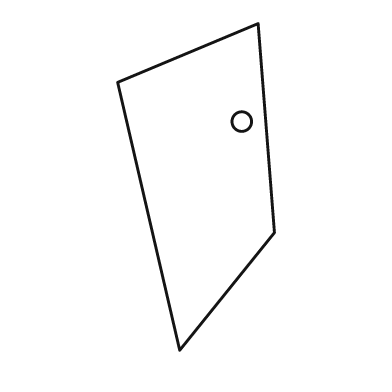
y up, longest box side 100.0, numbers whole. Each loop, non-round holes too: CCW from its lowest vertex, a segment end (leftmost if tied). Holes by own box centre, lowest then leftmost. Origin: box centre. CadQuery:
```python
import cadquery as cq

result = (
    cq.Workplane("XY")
    .moveTo(-5.0, -50.0)
    .lineTo(24.0, -14.0)
    .lineTo(19.0, 50.0)
    .lineTo(-24.0, 32.0)
    .close()
    .moveTo(14.0, 20.0)
    .circle(3.0)
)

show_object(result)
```